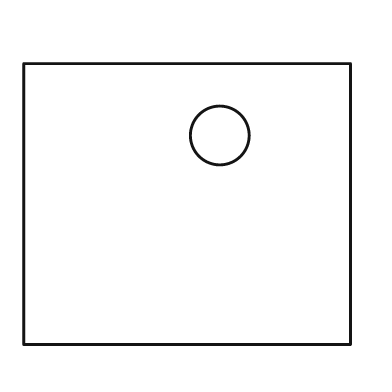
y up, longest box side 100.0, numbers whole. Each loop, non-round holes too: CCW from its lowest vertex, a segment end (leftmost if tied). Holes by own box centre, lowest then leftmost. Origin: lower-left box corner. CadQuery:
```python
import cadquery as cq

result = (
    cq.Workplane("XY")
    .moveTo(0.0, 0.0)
    .lineTo(100.0, 0.0)
    .lineTo(100.0, 86.0)
    .lineTo(0.0, 86.0)
    .close()
    .moveTo(60.0, 64.0)
    .circle(9.0)
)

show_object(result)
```